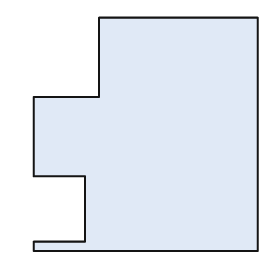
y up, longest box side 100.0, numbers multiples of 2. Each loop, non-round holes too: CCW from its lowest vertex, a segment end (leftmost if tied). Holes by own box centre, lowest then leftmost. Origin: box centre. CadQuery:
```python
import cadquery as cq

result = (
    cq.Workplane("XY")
    .moveTo(-48.0, -50.0)
    .lineTo(48.0, -50.0)
    .lineTo(48.0, 50.0)
    .lineTo(-20.0, 50.0)
    .lineTo(-20.0, 16.0)
    .lineTo(-48.0, 16.0)
    .lineTo(-48.0, -18.0)
    .lineTo(-26.0, -18.0)
    .lineTo(-26.0, -46.0)
    .lineTo(-48.0, -46.0)
    .close()
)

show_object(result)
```